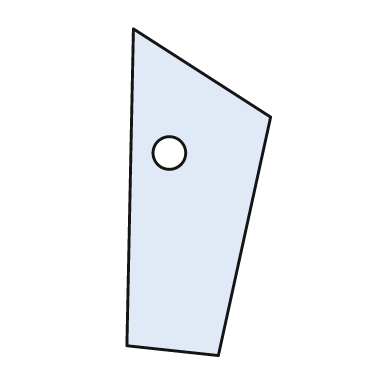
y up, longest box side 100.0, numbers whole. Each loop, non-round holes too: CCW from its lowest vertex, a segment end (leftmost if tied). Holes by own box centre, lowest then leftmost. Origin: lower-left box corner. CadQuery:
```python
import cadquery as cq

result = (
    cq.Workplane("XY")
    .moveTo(28.0, 0.0)
    .lineTo(44.0, 73.0)
    .lineTo(2.0, 100.0)
    .lineTo(0.0, 3.0)
    .close()
    .moveTo(13.0, 62.0)
    .circle(5.0)
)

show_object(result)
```